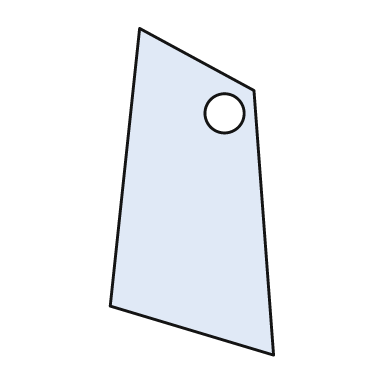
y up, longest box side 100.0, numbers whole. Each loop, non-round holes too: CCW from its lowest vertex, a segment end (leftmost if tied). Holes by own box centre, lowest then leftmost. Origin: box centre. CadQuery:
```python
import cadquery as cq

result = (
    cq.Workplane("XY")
    .moveTo(25.0, -50.0)
    .lineTo(19.0, 31.0)
    .lineTo(-16.0, 50.0)
    .lineTo(-25.0, -35.0)
    .close()
    .moveTo(10.0, 24.0)
    .circle(6.0)
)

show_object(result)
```